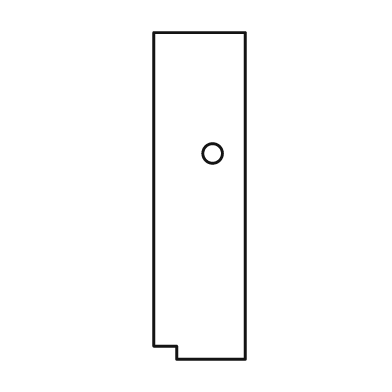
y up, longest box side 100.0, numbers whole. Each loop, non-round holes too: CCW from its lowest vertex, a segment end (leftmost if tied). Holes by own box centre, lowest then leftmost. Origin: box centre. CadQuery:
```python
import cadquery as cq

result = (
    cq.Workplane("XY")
    .moveTo(-7.0, -50.0)
    .lineTo(14.0, -50.0)
    .lineTo(14.0, 50.0)
    .lineTo(-14.0, 50.0)
    .lineTo(-14.0, -46.0)
    .lineTo(-7.0, -46.0)
    .close()
    .moveTo(4.0, 13.0)
    .circle(3.0)
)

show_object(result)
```